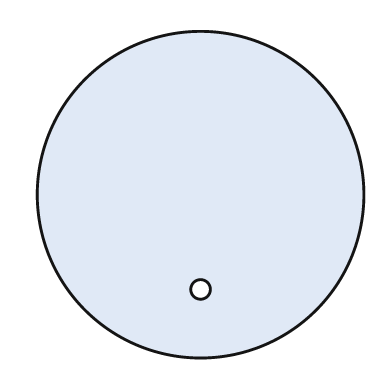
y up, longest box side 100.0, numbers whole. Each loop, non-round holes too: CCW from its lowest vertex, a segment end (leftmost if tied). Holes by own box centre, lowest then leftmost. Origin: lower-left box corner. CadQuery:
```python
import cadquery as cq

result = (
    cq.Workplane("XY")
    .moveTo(50.0, 50.0)
    .circle(50.0)
    .moveTo(50.0, 21.0)
    .circle(3.0)
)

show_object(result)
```